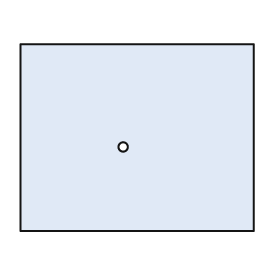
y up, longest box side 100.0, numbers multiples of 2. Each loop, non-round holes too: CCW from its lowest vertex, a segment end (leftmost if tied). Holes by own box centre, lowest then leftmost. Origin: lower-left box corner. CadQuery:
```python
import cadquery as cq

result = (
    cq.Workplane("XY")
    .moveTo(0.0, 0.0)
    .lineTo(100.0, 0.0)
    .lineTo(100.0, 80.0)
    .lineTo(0.0, 80.0)
    .close()
    .moveTo(44.0, 36.0)
    .circle(2.0)
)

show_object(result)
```